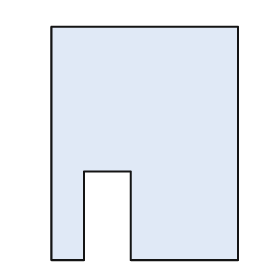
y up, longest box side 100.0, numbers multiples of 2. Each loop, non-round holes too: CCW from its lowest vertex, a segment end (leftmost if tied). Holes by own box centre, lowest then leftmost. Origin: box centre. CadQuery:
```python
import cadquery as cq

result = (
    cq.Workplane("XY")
    .moveTo(-40.0, -50.0)
    .lineTo(-26.0, -50.0)
    .lineTo(-26.0, -12.0)
    .lineTo(-6.0, -12.0)
    .lineTo(-6.0, -50.0)
    .lineTo(40.0, -50.0)
    .lineTo(40.0, 50.0)
    .lineTo(-40.0, 50.0)
    .close()
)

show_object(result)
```